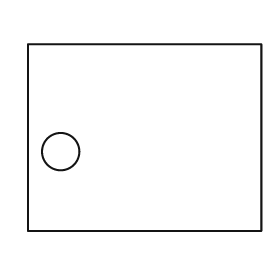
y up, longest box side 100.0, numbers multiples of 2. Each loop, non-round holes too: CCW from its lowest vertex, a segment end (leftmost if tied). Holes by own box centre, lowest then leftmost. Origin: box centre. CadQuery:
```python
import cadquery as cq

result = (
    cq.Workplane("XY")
    .moveTo(-50.0, -40.0)
    .lineTo(50.0, -40.0)
    .lineTo(50.0, 40.0)
    .lineTo(-50.0, 40.0)
    .close()
    .moveTo(-36.0, -6.0)
    .circle(8.0)
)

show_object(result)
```